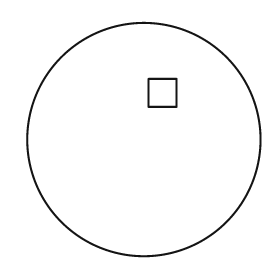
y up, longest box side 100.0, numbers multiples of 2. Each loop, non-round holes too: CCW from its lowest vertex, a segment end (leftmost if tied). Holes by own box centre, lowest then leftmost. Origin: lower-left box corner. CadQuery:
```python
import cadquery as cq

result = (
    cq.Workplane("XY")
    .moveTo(50.0, 50.0)
    .circle(50.0)
    .moveTo(52.0, 64.0)
    .lineTo(64.0, 64.0)
    .lineTo(64.0, 76.0)
    .lineTo(52.0, 76.0)
    .close()
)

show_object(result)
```